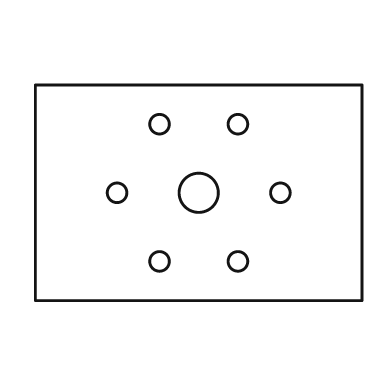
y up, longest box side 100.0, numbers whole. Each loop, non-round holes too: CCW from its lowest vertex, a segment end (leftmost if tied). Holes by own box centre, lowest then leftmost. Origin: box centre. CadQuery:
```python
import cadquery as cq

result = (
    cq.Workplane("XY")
    .moveTo(-50.0, -33.0)
    .lineTo(50.0, -33.0)
    .lineTo(50.0, 33.0)
    .lineTo(-50.0, 33.0)
    .close()
    .moveTo(-12.0, -21.0)
    .circle(3.0)
    .moveTo(12.0, -21.0)
    .circle(3.0)
    .moveTo(-25.0, 0.0)
    .circle(3.0)
    .moveTo(0.0, 0.0)
    .circle(6.0)
    .moveTo(25.0, 0.0)
    .circle(3.0)
    .moveTo(-12.0, 21.0)
    .circle(3.0)
    .moveTo(12.0, 21.0)
    .circle(3.0)
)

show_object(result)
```